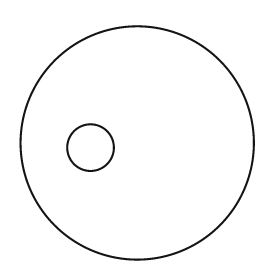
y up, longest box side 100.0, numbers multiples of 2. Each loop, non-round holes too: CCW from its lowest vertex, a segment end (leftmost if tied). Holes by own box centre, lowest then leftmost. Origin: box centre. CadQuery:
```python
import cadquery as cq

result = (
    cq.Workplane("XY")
    .moveTo(0.0, 0.0)
    .circle(50.0)
    .moveTo(-20.0, -2.0)
    .circle(10.0)
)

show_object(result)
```